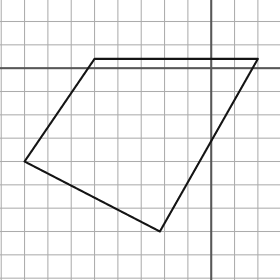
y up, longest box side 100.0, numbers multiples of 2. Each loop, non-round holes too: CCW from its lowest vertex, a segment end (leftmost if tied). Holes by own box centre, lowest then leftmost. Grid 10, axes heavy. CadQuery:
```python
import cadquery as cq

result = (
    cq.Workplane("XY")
    .moveTo(-22.0, -70.0)
    .lineTo(20.0, 4.0)
    .lineTo(-50.0, 4.0)
    .lineTo(-80.0, -40.0)
    .close()
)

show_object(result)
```